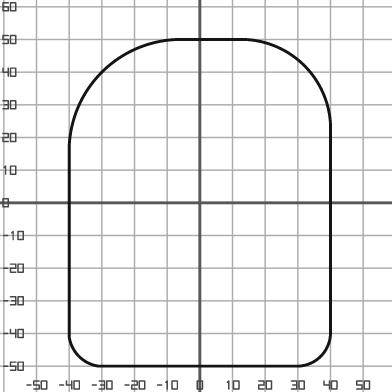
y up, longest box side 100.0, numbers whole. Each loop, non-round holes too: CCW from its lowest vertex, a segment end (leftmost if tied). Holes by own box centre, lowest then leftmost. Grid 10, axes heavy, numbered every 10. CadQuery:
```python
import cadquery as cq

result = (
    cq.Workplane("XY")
    .moveTo(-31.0, -50.0)
    .lineTo(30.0, -50.0)
    .threePointArc((37.0, -47.0), (40.0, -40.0))
    .lineTo(40.0, 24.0)
    .threePointArc((32.0, 42.0), (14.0, 50.0))
    .lineTo(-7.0, 50.0)
    .threePointArc((-30.0, 40.0), (-40.0, 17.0))
    .lineTo(-40.0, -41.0)
    .threePointArc((-37.0, -47.0), (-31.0, -50.0))
    .close()
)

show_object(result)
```